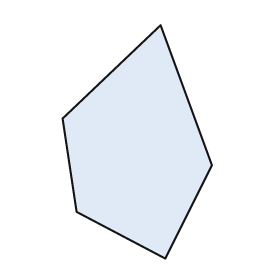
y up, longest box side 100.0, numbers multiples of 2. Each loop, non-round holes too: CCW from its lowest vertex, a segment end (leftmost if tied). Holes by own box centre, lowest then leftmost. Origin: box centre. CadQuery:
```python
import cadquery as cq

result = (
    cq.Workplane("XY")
    .moveTo(12.0, -50.0)
    .lineTo(32.0, -10.0)
    .lineTo(10.0, 50.0)
    .lineTo(-32.0, 10.0)
    .lineTo(-26.0, -30.0)
    .close()
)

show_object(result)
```